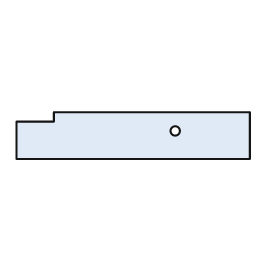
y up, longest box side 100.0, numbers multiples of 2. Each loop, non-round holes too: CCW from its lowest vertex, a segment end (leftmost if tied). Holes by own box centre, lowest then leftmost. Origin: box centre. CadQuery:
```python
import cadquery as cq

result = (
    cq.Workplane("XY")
    .moveTo(-50.0, -10.0)
    .lineTo(50.0, -10.0)
    .lineTo(50.0, 10.0)
    .lineTo(-34.0, 10.0)
    .lineTo(-34.0, 6.0)
    .lineTo(-50.0, 6.0)
    .close()
    .moveTo(18.0, 2.0)
    .circle(2.0)
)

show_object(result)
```